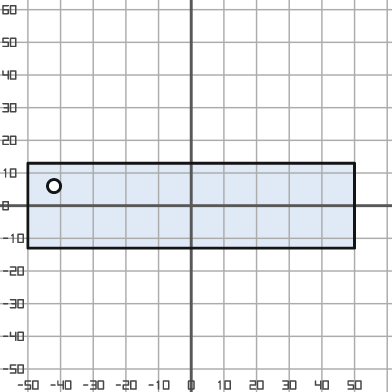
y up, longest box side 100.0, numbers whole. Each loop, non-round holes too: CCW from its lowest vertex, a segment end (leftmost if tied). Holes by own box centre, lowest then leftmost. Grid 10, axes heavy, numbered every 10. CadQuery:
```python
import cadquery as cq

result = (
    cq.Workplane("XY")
    .moveTo(-50.0, -13.0)
    .lineTo(50.0, -13.0)
    .lineTo(50.0, 13.0)
    .lineTo(-50.0, 13.0)
    .close()
    .moveTo(-42.0, 6.0)
    .circle(2.0)
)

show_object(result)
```